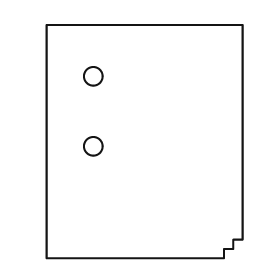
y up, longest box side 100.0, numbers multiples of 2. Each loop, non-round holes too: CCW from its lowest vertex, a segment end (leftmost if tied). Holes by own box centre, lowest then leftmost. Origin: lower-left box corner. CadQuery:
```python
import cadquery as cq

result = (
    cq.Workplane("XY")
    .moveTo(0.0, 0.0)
    .lineTo(76.0, 0.0)
    .lineTo(76.0, 4.0)
    .lineTo(80.0, 4.0)
    .lineTo(80.0, 8.0)
    .lineTo(84.0, 8.0)
    .lineTo(84.0, 100.0)
    .lineTo(0.0, 100.0)
    .close()
    .moveTo(20.0, 48.0)
    .circle(4.0)
    .moveTo(20.0, 78.0)
    .circle(4.0)
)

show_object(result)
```